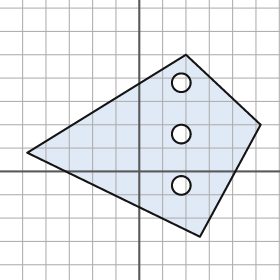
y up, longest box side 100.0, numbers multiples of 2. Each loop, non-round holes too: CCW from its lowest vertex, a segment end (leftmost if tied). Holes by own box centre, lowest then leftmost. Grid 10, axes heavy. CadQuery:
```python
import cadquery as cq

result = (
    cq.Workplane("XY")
    .moveTo(26.0, -28.0)
    .lineTo(52.0, 20.0)
    .lineTo(20.0, 50.0)
    .lineTo(-48.0, 8.0)
    .close()
    .moveTo(18.0, -6.0)
    .circle(4.0)
    .moveTo(18.0, 16.0)
    .circle(4.0)
    .moveTo(18.0, 38.0)
    .circle(4.0)
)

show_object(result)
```